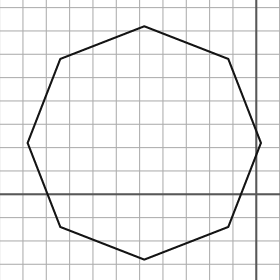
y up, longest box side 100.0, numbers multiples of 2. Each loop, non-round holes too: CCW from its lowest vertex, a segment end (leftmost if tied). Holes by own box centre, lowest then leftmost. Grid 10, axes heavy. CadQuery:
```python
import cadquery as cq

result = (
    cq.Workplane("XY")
    .moveTo(-48.0, -28.0)
    .lineTo(-12.0, -14.0)
    .lineTo(2.0, 22.0)
    .lineTo(-12.0, 58.0)
    .lineTo(-48.0, 72.0)
    .lineTo(-84.0, 58.0)
    .lineTo(-98.0, 22.0)
    .lineTo(-84.0, -14.0)
    .close()
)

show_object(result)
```